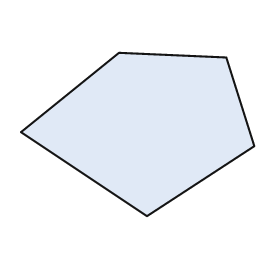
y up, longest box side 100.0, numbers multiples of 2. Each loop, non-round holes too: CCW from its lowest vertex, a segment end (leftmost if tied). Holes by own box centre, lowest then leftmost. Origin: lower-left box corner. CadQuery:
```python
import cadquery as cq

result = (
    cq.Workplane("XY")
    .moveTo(54.0, 0.0)
    .lineTo(100.0, 30.0)
    .lineTo(88.0, 68.0)
    .lineTo(42.0, 70.0)
    .lineTo(0.0, 36.0)
    .close()
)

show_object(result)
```